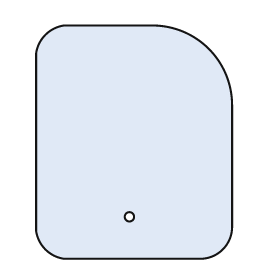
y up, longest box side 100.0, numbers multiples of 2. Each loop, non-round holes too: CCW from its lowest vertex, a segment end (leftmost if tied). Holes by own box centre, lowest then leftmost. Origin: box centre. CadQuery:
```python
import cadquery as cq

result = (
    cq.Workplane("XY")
    .moveTo(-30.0, -50.0)
    .lineTo(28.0, -50.0)
    .threePointArc((38.0, -46.0), (42.0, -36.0))
    .lineTo(42.0, 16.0)
    .threePointArc((32.0, 40.0), (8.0, 50.0))
    .lineTo(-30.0, 50.0)
    .threePointArc((-38.0, 46.0), (-42.0, 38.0))
    .lineTo(-42.0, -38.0)
    .threePointArc((-38.0, -46.0), (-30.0, -50.0))
    .close()
    .moveTo(-2.0, -32.0)
    .circle(2.0)
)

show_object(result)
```